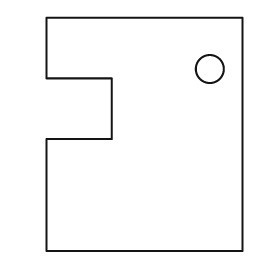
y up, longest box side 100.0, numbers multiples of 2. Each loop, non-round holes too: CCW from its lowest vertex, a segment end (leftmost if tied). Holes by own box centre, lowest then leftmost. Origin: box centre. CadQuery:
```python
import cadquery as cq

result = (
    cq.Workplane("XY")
    .moveTo(-42.0, -50.0)
    .lineTo(42.0, -50.0)
    .lineTo(42.0, 50.0)
    .lineTo(-42.0, 50.0)
    .lineTo(-42.0, 24.0)
    .lineTo(-14.0, 24.0)
    .lineTo(-14.0, -2.0)
    .lineTo(-42.0, -2.0)
    .close()
    .moveTo(28.0, 28.0)
    .circle(6.0)
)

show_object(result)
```